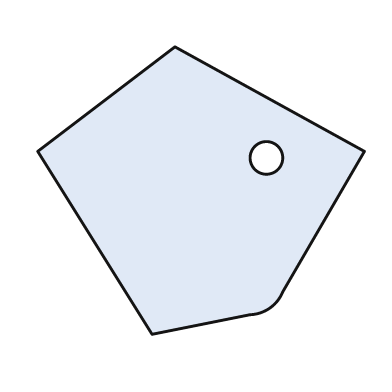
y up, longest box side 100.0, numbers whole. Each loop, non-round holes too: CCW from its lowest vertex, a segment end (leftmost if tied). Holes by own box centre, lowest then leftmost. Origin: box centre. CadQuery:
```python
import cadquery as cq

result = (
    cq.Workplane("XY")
    .moveTo(-15.0, -44.0)
    .lineTo(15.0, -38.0)
    .threePointArc((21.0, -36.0), (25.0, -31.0))
    .lineTo(50.0, 12.0)
    .lineTo(-8.0, 44.0)
    .lineTo(-50.0, 12.0)
    .close()
    .moveTo(20.0, 10.0)
    .circle(5.0)
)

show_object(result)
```